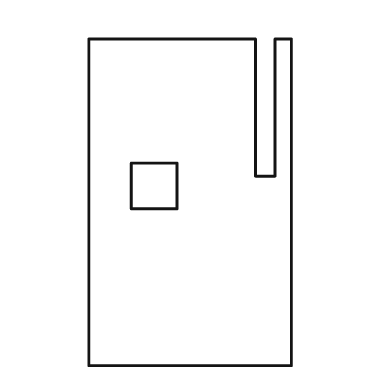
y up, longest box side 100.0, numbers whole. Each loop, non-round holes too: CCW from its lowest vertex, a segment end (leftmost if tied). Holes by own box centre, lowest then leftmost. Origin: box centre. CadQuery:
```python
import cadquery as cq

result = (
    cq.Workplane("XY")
    .moveTo(-31.0, -50.0)
    .lineTo(31.0, -50.0)
    .lineTo(31.0, 50.0)
    .lineTo(26.0, 50.0)
    .lineTo(26.0, 8.0)
    .lineTo(20.0, 8.0)
    .lineTo(20.0, 50.0)
    .lineTo(-31.0, 50.0)
    .close()
    .moveTo(-18.0, -2.0)
    .lineTo(-4.0, -2.0)
    .lineTo(-4.0, 12.0)
    .lineTo(-18.0, 12.0)
    .close()
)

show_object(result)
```